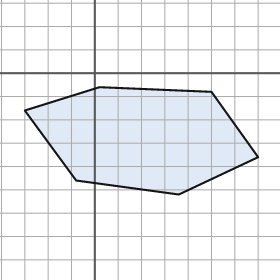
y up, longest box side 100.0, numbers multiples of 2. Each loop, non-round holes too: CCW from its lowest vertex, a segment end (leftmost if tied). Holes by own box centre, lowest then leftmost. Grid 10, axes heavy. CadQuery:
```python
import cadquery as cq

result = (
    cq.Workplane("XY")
    .moveTo(36.0, -52.0)
    .lineTo(70.0, -36.0)
    .lineTo(50.0, -8.0)
    .lineTo(2.0, -6.0)
    .lineTo(-30.0, -16.0)
    .lineTo(-8.0, -46.0)
    .close()
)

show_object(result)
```